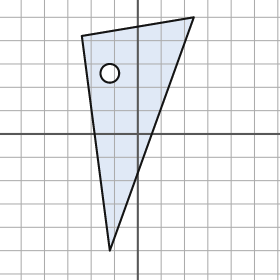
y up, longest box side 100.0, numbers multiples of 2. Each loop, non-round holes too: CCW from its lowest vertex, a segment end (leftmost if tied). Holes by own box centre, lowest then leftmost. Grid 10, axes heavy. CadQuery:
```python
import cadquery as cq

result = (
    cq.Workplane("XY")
    .moveTo(-12.0, -50.0)
    .lineTo(24.0, 50.0)
    .lineTo(-24.0, 42.0)
    .close()
    .moveTo(-12.0, 26.0)
    .circle(4.0)
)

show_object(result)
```